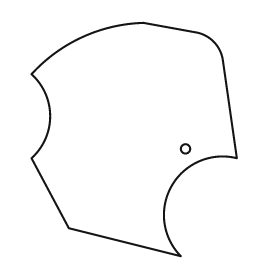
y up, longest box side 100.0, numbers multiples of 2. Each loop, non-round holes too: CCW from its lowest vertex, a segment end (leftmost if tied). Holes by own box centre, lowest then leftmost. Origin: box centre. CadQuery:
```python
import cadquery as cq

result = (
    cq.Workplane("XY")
    .moveTo(20.0, -50.0)
    .threePointArc((16.0, -20.0), (44.0, -8.0))
    .lineTo(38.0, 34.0)
    .threePointArc((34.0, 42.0), (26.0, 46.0))
    .lineTo(4.0, 50.0)
    .threePointArc((-22.0, 44.0), (-44.0, 28.0))
    .threePointArc((-36.0, 10.0), (-44.0, -8.0))
    .lineTo(-28.0, -38.0)
    .close()
    .moveTo(22.0, -4.0)
    .circle(2.0)
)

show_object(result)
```